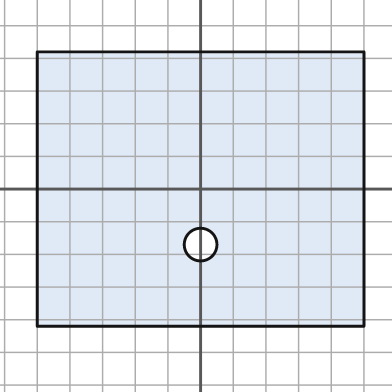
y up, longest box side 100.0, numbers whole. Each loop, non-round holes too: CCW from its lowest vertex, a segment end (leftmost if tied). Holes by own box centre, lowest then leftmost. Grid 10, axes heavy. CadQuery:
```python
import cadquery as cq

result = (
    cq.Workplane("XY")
    .moveTo(-50.0, -42.0)
    .lineTo(50.0, -42.0)
    .lineTo(50.0, 42.0)
    .lineTo(-50.0, 42.0)
    .close()
    .moveTo(0.0, -17.0)
    .circle(5.0)
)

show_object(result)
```